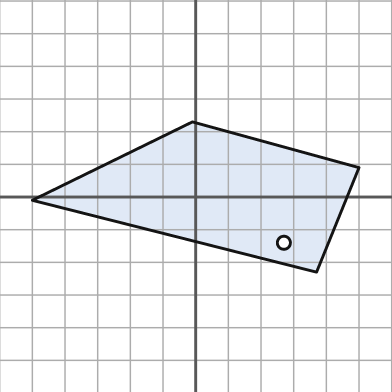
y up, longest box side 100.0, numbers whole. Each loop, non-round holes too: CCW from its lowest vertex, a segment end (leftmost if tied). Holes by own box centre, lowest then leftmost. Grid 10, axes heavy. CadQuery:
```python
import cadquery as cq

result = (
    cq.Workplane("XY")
    .moveTo(37.0, -23.0)
    .lineTo(50.0, 9.0)
    .lineTo(-1.0, 23.0)
    .lineTo(-50.0, -1.0)
    .close()
    .moveTo(27.0, -14.0)
    .circle(2.0)
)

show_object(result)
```